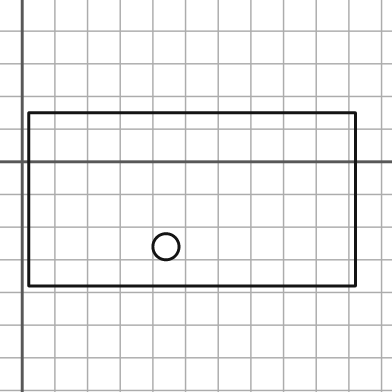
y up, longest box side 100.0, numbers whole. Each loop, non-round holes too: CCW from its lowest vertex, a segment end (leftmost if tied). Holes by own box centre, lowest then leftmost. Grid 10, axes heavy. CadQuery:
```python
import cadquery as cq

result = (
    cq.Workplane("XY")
    .moveTo(2.0, -38.0)
    .lineTo(102.0, -38.0)
    .lineTo(102.0, 15.0)
    .lineTo(2.0, 15.0)
    .close()
    .moveTo(44.0, -26.0)
    .circle(4.0)
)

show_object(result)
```